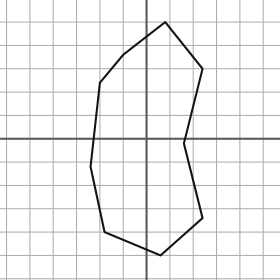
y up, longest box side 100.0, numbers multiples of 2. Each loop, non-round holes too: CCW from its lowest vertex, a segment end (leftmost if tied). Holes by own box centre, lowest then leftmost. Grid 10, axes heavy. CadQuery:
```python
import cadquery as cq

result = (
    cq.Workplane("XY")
    .moveTo(6.0, -50.0)
    .lineTo(24.0, -34.0)
    .lineTo(16.0, -2.0)
    .lineTo(24.0, 30.0)
    .lineTo(8.0, 50.0)
    .lineTo(-10.0, 36.0)
    .lineTo(-20.0, 24.0)
    .lineTo(-24.0, -12.0)
    .lineTo(-18.0, -40.0)
    .close()
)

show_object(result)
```